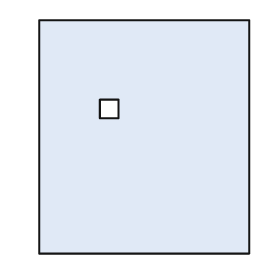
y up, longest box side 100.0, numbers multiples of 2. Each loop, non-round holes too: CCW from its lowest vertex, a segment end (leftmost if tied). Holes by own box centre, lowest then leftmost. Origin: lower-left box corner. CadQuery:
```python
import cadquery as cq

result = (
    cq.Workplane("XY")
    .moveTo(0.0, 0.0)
    .lineTo(90.0, 0.0)
    .lineTo(90.0, 100.0)
    .lineTo(0.0, 100.0)
    .close()
    .moveTo(26.0, 58.0)
    .lineTo(34.0, 58.0)
    .lineTo(34.0, 66.0)
    .lineTo(26.0, 66.0)
    .close()
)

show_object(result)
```